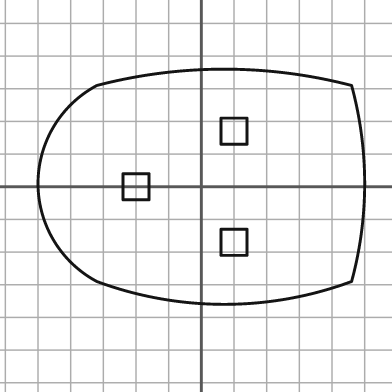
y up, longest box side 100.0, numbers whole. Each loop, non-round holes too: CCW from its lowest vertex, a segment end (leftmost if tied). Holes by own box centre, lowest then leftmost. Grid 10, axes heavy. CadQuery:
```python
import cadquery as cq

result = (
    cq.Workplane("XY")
    .moveTo(-32.0, -29.0)
    .threePointArc((7.0, -36.0), (46.0, -29.0))
    .threePointArc((50.0, 1.0), (46.0, 31.0))
    .threePointArc((7.0, 36.0), (-32.0, 31.0))
    .threePointArc((-50.0, 1.0), (-32.0, -29.0))
    .close()
    .moveTo(6.0, -21.0)
    .lineTo(14.0, -21.0)
    .lineTo(14.0, -13.0)
    .lineTo(6.0, -13.0)
    .close()
    .moveTo(-24.0, -4.0)
    .lineTo(-16.0, -4.0)
    .lineTo(-16.0, 4.0)
    .lineTo(-24.0, 4.0)
    .close()
    .moveTo(6.0, 13.0)
    .lineTo(14.0, 13.0)
    .lineTo(14.0, 21.0)
    .lineTo(6.0, 21.0)
    .close()
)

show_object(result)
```